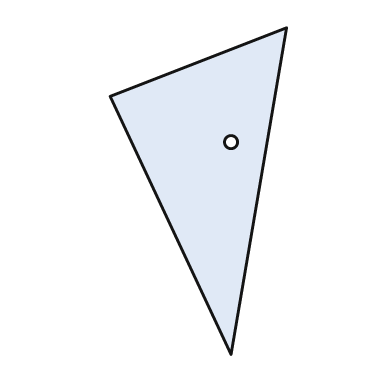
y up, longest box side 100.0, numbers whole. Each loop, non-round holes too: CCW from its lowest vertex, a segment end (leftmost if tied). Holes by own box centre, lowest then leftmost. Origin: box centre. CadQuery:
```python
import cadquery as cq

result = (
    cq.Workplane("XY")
    .moveTo(10.0, -50.0)
    .lineTo(27.0, 50.0)
    .lineTo(-27.0, 29.0)
    .close()
    .moveTo(10.0, 15.0)
    .circle(2.0)
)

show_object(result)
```